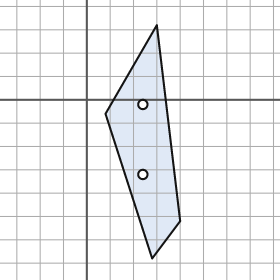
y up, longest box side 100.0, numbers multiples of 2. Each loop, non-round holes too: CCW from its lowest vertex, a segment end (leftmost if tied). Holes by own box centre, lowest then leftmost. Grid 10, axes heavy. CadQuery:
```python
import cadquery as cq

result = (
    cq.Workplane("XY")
    .moveTo(28.0, -68.0)
    .lineTo(40.0, -52.0)
    .lineTo(30.0, 32.0)
    .lineTo(8.0, -6.0)
    .close()
    .moveTo(24.0, -32.0)
    .circle(2.0)
    .moveTo(24.0, -2.0)
    .circle(2.0)
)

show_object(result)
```